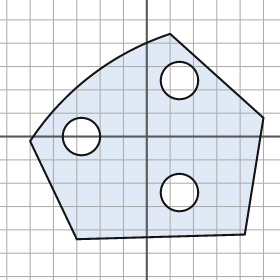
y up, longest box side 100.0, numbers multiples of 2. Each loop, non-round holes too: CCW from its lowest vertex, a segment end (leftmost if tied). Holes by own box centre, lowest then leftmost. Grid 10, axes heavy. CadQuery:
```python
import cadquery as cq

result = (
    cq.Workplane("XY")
    .moveTo(-30.0, -44.0)
    .lineTo(42.0, -42.0)
    .lineTo(50.0, 8.0)
    .lineTo(10.0, 44.0)
    .threePointArc((-24.0, 26.0), (-50.0, -2.0))
    .close()
    .moveTo(14.0, -24.0)
    .circle(8.0)
    .moveTo(-28.0, 0.0)
    .circle(8.0)
    .moveTo(14.0, 24.0)
    .circle(8.0)
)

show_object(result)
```